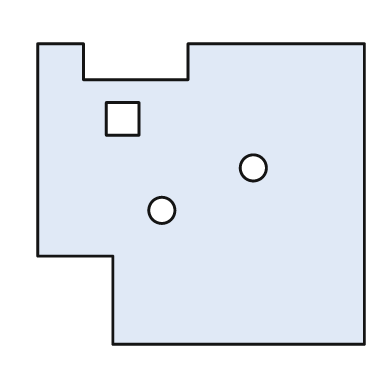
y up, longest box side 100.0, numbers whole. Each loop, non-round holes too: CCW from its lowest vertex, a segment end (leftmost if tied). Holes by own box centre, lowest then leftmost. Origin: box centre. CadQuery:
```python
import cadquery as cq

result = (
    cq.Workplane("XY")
    .moveTo(-27.0, -46.0)
    .lineTo(50.0, -46.0)
    .lineTo(50.0, 46.0)
    .lineTo(-4.0, 46.0)
    .lineTo(-4.0, 35.0)
    .lineTo(-36.0, 35.0)
    .lineTo(-36.0, 46.0)
    .lineTo(-50.0, 46.0)
    .lineTo(-50.0, -19.0)
    .lineTo(-27.0, -19.0)
    .close()
    .moveTo(-12.0, -5.0)
    .circle(4.0)
    .moveTo(16.0, 8.0)
    .circle(4.0)
    .moveTo(-29.0, 18.0)
    .lineTo(-19.0, 18.0)
    .lineTo(-19.0, 28.0)
    .lineTo(-29.0, 28.0)
    .close()
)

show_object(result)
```